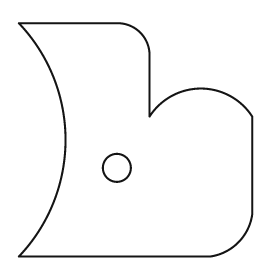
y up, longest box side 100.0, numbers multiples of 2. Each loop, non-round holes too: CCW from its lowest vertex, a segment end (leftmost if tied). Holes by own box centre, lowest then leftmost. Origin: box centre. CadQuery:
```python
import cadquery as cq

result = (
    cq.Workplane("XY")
    .moveTo(-50.0, -50.0)
    .lineTo(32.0, -50.0)
    .threePointArc((44.0, -44.0), (50.0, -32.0))
    .lineTo(50.0, 10.0)
    .threePointArc((28.0, 22.0), (6.0, 10.0))
    .lineTo(6.0, 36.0)
    .threePointArc((2.0, 46.0), (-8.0, 50.0))
    .lineTo(-50.0, 50.0)
    .threePointArc((-30.0, 0.0), (-50.0, -50.0))
    .close()
    .moveTo(-8.0, -12.0)
    .circle(6.0)
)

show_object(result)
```